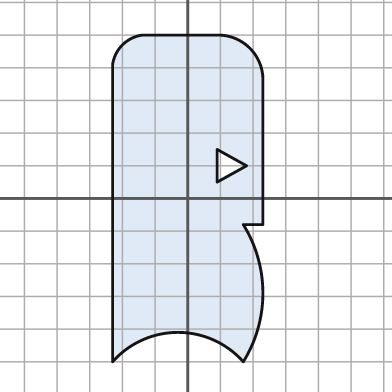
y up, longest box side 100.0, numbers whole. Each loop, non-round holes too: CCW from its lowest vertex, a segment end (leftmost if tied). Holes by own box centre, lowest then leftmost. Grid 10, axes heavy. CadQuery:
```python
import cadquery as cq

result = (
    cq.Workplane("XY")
    .moveTo(-23.0, -50.0)
    .threePointArc((-3.0, -41.0), (17.0, -50.0))
    .threePointArc((23.0, -29.0), (17.0, -8.0))
    .lineTo(23.0, -8.0)
    .lineTo(23.0, 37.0)
    .threePointArc((19.0, 46.0), (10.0, 50.0))
    .lineTo(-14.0, 50.0)
    .threePointArc((-20.0, 47.0), (-23.0, 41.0))
    .close()
    .moveTo(9.0, 5.0)
    .lineTo(18.0, 10.0)
    .lineTo(9.0, 15.0)
    .close()
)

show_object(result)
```